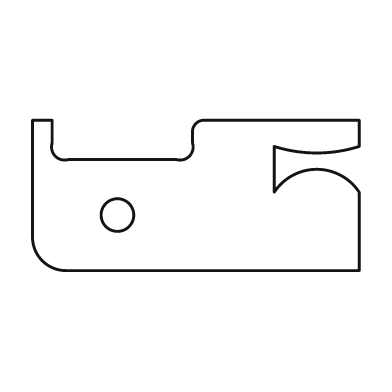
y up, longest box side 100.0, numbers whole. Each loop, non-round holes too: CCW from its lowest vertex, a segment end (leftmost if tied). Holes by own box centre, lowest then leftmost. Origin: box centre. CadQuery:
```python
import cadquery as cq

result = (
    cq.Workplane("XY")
    .moveTo(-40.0, -23.0)
    .lineTo(50.0, -23.0)
    .lineTo(50.0, 1.0)
    .threePointArc((37.0, 8.0), (24.0, 1.0))
    .lineTo(24.0, 15.0)
    .threePointArc((37.0, 13.0), (50.0, 15.0))
    .lineTo(50.0, 23.0)
    .lineTo(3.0, 23.0)
    .threePointArc((0.0, 22.0), (-1.0, 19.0))
    .lineTo(-1.0, 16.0)
    .threePointArc((-2.0, 12.0), (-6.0, 11.0))
    .lineTo(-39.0, 11.0)
    .threePointArc((-43.0, 12.0), (-44.0, 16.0))
    .lineTo(-44.0, 23.0)
    .lineTo(-50.0, 23.0)
    .lineTo(-50.0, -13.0)
    .threePointArc((-47.0, -20.0), (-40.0, -23.0))
    .close()
    .moveTo(-24.0, -6.0)
    .circle(5.0)
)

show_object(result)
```